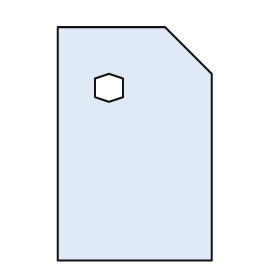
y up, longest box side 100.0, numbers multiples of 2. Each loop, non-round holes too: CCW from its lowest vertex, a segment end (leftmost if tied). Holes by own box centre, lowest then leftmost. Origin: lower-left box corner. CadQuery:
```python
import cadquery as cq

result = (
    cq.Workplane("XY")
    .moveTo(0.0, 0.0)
    .lineTo(66.0, 0.0)
    .lineTo(66.0, 80.0)
    .lineTo(46.0, 100.0)
    .lineTo(0.0, 100.0)
    .close()
    .moveTo(22.0, 68.0)
    .lineTo(28.0, 70.0)
    .lineTo(28.0, 78.0)
    .lineTo(22.0, 80.0)
    .lineTo(16.0, 78.0)
    .lineTo(16.0, 70.0)
    .close()
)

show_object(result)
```